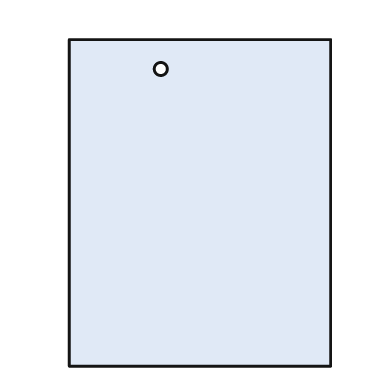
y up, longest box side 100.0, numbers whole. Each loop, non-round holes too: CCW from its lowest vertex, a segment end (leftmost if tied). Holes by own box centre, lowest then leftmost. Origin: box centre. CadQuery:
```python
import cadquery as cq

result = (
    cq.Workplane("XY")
    .moveTo(-40.0, -50.0)
    .lineTo(40.0, -50.0)
    .lineTo(40.0, 50.0)
    .lineTo(-40.0, 50.0)
    .close()
    .moveTo(-12.0, 41.0)
    .circle(2.0)
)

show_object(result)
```